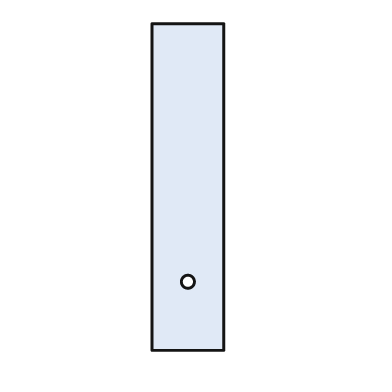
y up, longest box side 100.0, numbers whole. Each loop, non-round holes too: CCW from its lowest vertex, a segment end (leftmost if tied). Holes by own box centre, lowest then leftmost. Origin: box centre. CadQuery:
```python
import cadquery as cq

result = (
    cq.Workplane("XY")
    .moveTo(-11.0, -50.0)
    .lineTo(11.0, -50.0)
    .lineTo(11.0, 50.0)
    .lineTo(-11.0, 50.0)
    .close()
    .moveTo(0.0, -29.0)
    .circle(2.0)
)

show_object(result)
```